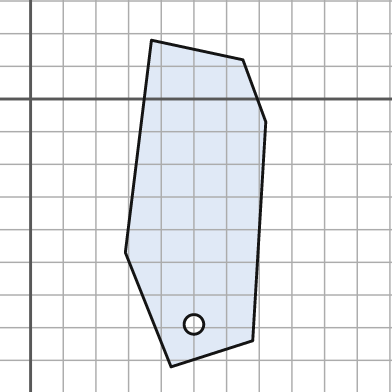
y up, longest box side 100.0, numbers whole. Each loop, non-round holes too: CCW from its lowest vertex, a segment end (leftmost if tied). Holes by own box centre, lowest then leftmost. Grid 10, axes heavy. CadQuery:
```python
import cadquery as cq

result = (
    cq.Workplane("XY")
    .moveTo(43.0, -82.0)
    .lineTo(68.0, -74.0)
    .lineTo(72.0, -7.0)
    .lineTo(65.0, 12.0)
    .lineTo(37.0, 18.0)
    .lineTo(29.0, -47.0)
    .close()
    .moveTo(50.0, -69.0)
    .circle(3.0)
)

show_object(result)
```